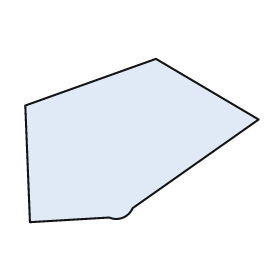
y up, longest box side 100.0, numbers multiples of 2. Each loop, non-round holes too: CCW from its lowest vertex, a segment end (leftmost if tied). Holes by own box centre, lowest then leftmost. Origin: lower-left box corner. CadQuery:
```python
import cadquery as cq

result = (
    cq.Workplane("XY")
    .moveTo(2.0, 0.0)
    .lineTo(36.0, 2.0)
    .threePointArc((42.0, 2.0), (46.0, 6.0))
    .lineTo(100.0, 44.0)
    .lineTo(56.0, 70.0)
    .lineTo(0.0, 50.0)
    .close()
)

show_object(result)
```